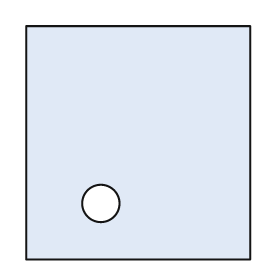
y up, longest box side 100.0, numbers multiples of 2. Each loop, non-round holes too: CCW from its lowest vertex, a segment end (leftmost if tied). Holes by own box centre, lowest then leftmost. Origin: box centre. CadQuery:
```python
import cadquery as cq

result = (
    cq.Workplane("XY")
    .moveTo(-48.0, -50.0)
    .lineTo(48.0, -50.0)
    .lineTo(48.0, 50.0)
    .lineTo(-48.0, 50.0)
    .close()
    .moveTo(-16.0, -26.0)
    .circle(8.0)
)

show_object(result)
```